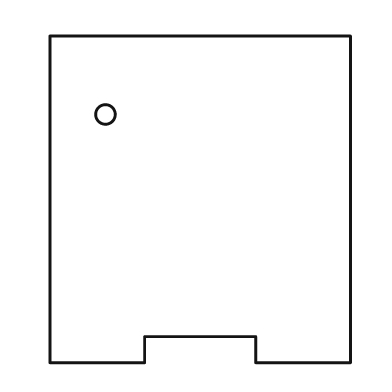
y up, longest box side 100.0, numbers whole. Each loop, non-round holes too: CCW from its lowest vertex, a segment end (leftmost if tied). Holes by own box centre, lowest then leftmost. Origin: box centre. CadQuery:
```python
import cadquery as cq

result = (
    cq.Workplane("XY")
    .moveTo(-46.0, -50.0)
    .lineTo(-17.0, -50.0)
    .lineTo(-17.0, -42.0)
    .lineTo(17.0, -42.0)
    .lineTo(17.0, -50.0)
    .lineTo(46.0, -50.0)
    .lineTo(46.0, 50.0)
    .lineTo(-46.0, 50.0)
    .close()
    .moveTo(-29.0, 26.0)
    .circle(3.0)
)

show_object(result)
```